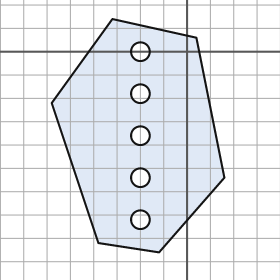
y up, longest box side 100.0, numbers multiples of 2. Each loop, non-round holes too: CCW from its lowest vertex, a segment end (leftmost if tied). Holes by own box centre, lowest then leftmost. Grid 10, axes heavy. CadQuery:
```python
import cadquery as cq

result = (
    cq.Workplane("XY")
    .moveTo(-12.0, -86.0)
    .lineTo(16.0, -54.0)
    .lineTo(4.0, 6.0)
    .lineTo(-32.0, 14.0)
    .lineTo(-58.0, -22.0)
    .lineTo(-38.0, -82.0)
    .close()
    .moveTo(-20.0, -72.0)
    .circle(4.0)
    .moveTo(-20.0, -54.0)
    .circle(4.0)
    .moveTo(-20.0, -36.0)
    .circle(4.0)
    .moveTo(-20.0, -18.0)
    .circle(4.0)
    .moveTo(-20.0, 0.0)
    .circle(4.0)
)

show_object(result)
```